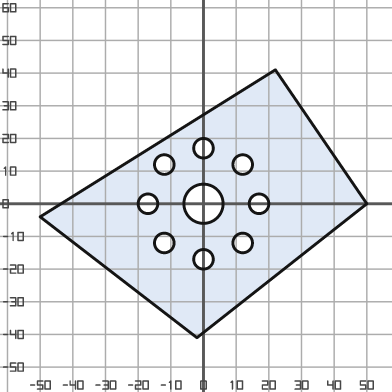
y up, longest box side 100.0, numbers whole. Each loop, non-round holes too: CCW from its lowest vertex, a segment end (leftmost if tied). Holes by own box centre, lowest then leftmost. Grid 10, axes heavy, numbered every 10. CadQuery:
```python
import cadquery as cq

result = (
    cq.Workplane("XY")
    .moveTo(-2.0, -41.0)
    .lineTo(50.0, 0.0)
    .lineTo(22.0, 41.0)
    .lineTo(-50.0, -4.0)
    .close()
    .moveTo(0.0, -17.0)
    .circle(3.0)
    .moveTo(-12.0, -12.0)
    .circle(3.0)
    .moveTo(12.0, -12.0)
    .circle(3.0)
    .moveTo(-17.0, 0.0)
    .circle(3.0)
    .moveTo(0.0, 0.0)
    .circle(6.0)
    .moveTo(17.0, 0.0)
    .circle(3.0)
    .moveTo(-12.0, 12.0)
    .circle(3.0)
    .moveTo(12.0, 12.0)
    .circle(3.0)
    .moveTo(0.0, 17.0)
    .circle(3.0)
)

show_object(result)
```